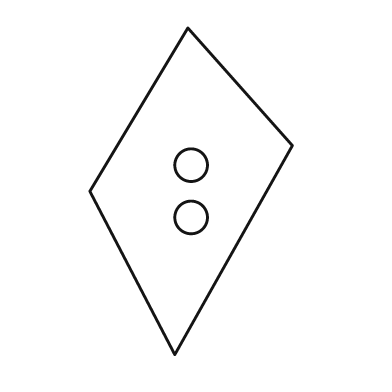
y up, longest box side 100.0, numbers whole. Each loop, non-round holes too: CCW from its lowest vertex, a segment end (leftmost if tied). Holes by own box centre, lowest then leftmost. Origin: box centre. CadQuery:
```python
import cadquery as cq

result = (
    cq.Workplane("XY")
    .moveTo(-5.0, -50.0)
    .lineTo(31.0, 14.0)
    .lineTo(-1.0, 50.0)
    .lineTo(-31.0, 0.0)
    .close()
    .moveTo(0.0, -8.0)
    .circle(5.0)
    .moveTo(0.0, 8.0)
    .circle(5.0)
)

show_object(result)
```